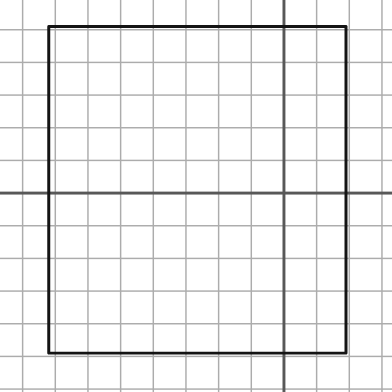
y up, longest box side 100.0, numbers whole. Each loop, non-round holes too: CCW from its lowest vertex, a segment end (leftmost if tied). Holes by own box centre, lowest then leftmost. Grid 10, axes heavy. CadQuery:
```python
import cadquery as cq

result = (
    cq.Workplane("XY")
    .moveTo(-72.0, -49.0)
    .lineTo(19.0, -49.0)
    .lineTo(19.0, 51.0)
    .lineTo(-72.0, 51.0)
    .close()
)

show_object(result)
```